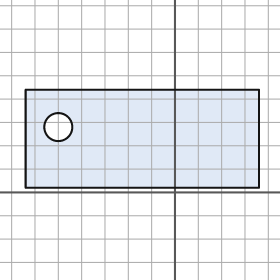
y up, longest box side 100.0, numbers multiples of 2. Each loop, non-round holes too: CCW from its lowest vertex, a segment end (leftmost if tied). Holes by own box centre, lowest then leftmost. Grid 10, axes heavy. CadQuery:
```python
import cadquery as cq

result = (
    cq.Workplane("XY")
    .moveTo(-64.0, 2.0)
    .lineTo(36.0, 2.0)
    .lineTo(36.0, 44.0)
    .lineTo(-64.0, 44.0)
    .close()
    .moveTo(-50.0, 28.0)
    .circle(6.0)
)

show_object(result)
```